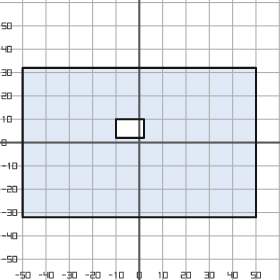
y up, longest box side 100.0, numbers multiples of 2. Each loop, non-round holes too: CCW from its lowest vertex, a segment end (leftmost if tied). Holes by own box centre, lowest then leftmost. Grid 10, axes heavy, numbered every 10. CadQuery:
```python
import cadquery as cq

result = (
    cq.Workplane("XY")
    .moveTo(-50.0, -32.0)
    .lineTo(50.0, -32.0)
    .lineTo(50.0, 32.0)
    .lineTo(-50.0, 32.0)
    .close()
    .moveTo(-10.0, 2.0)
    .lineTo(2.0, 2.0)
    .lineTo(2.0, 10.0)
    .lineTo(-10.0, 10.0)
    .close()
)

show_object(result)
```